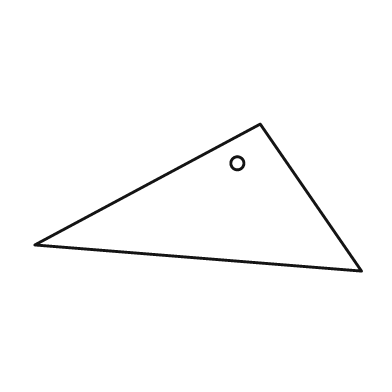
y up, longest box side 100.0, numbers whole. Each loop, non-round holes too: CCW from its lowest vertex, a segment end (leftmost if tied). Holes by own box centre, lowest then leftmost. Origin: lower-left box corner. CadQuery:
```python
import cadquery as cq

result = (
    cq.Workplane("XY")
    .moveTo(100.0, 0.0)
    .lineTo(69.0, 45.0)
    .lineTo(0.0, 8.0)
    .close()
    .moveTo(62.0, 33.0)
    .circle(2.0)
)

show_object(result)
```